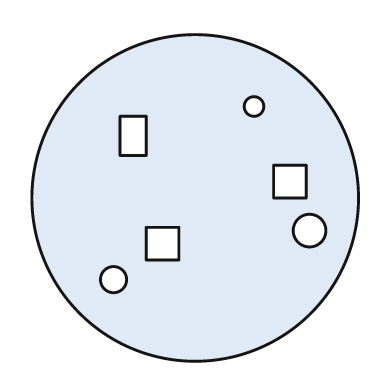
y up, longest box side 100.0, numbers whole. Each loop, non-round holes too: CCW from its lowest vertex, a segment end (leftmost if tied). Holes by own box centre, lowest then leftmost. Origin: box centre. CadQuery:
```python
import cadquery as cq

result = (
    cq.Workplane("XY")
    .moveTo(0.0, 0.0)
    .circle(50.0)
    .moveTo(-25.0, -25.0)
    .circle(4.0)
    .moveTo(-15.0, -19.0)
    .lineTo(-5.0, -19.0)
    .lineTo(-5.0, -9.0)
    .lineTo(-15.0, -9.0)
    .close()
    .moveTo(35.0, -10.0)
    .circle(5.0)
    .moveTo(24.0, 0.0)
    .lineTo(34.0, 0.0)
    .lineTo(34.0, 10.0)
    .lineTo(24.0, 10.0)
    .close()
    .moveTo(-23.0, 13.0)
    .lineTo(-15.0, 13.0)
    .lineTo(-15.0, 25.0)
    .lineTo(-23.0, 25.0)
    .close()
    .moveTo(18.0, 28.0)
    .circle(3.0)
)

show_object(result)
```